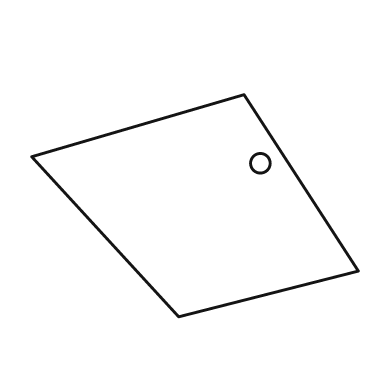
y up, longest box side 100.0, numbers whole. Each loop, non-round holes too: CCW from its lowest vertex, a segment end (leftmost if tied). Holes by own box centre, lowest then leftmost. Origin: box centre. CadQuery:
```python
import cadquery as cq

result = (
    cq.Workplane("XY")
    .moveTo(-5.0, -34.0)
    .lineTo(50.0, -20.0)
    .lineTo(15.0, 34.0)
    .lineTo(-50.0, 15.0)
    .close()
    .moveTo(20.0, 13.0)
    .circle(3.0)
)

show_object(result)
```